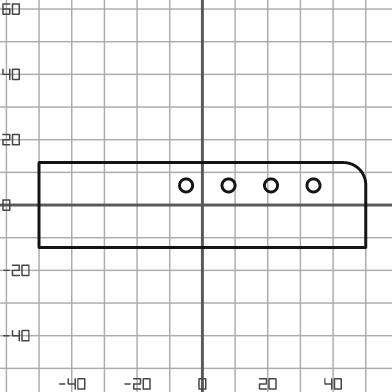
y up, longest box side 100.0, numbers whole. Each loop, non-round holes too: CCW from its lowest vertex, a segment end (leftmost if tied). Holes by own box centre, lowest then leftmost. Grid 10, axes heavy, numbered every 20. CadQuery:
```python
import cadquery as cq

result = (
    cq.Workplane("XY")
    .moveTo(-50.0, -13.0)
    .lineTo(50.0, -13.0)
    .lineTo(50.0, 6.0)
    .threePointArc((48.0, 11.0), (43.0, 13.0))
    .lineTo(-50.0, 13.0)
    .close()
    .moveTo(-5.0, 6.0)
    .circle(2.0)
    .moveTo(8.0, 6.0)
    .circle(2.0)
    .moveTo(21.0, 6.0)
    .circle(2.0)
    .moveTo(34.0, 6.0)
    .circle(2.0)
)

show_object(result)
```